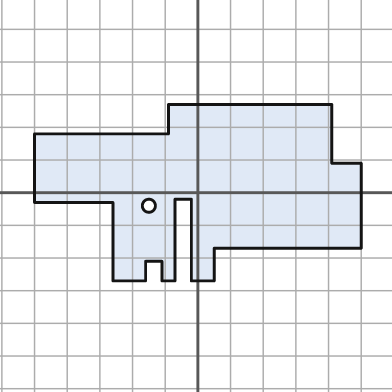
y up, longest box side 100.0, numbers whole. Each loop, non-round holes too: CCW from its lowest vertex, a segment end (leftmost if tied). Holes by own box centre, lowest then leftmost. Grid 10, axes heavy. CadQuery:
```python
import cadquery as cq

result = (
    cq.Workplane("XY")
    .moveTo(-26.0, -27.0)
    .lineTo(-16.0, -27.0)
    .lineTo(-16.0, -21.0)
    .lineTo(-11.0, -21.0)
    .lineTo(-11.0, -27.0)
    .lineTo(-7.0, -27.0)
    .lineTo(-7.0, -2.0)
    .lineTo(-2.0, -2.0)
    .lineTo(-2.0, -27.0)
    .lineTo(5.0, -27.0)
    .lineTo(5.0, -17.0)
    .lineTo(50.0, -17.0)
    .lineTo(50.0, 9.0)
    .lineTo(41.0, 9.0)
    .lineTo(41.0, 27.0)
    .lineTo(-9.0, 27.0)
    .lineTo(-9.0, 18.0)
    .lineTo(-50.0, 18.0)
    .lineTo(-50.0, -3.0)
    .lineTo(-26.0, -3.0)
    .close()
    .moveTo(-15.0, -4.0)
    .circle(2.0)
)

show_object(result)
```